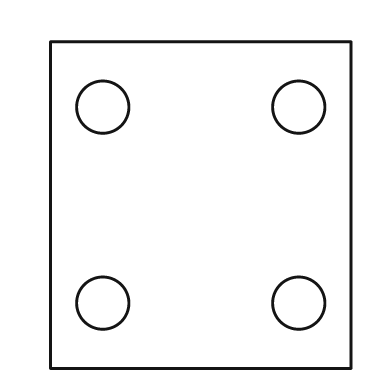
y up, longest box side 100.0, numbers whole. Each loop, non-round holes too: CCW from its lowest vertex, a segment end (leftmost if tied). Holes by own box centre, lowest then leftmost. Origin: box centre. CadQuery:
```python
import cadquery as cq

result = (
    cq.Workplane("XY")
    .moveTo(-46.0, -50.0)
    .lineTo(46.0, -50.0)
    .lineTo(46.0, 50.0)
    .lineTo(-46.0, 50.0)
    .close()
    .moveTo(-30.0, -30.0)
    .circle(8.0)
    .moveTo(30.0, -30.0)
    .circle(8.0)
    .moveTo(-30.0, 30.0)
    .circle(8.0)
    .moveTo(30.0, 30.0)
    .circle(8.0)
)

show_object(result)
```